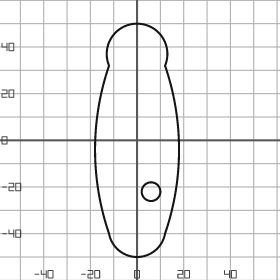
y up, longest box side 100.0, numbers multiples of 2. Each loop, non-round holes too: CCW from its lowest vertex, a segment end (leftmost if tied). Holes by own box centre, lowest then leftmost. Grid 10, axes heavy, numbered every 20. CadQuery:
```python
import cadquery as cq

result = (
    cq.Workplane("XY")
    .moveTo(-12.0, -40.0)
    .threePointArc((0.0, -50.0), (12.0, -40.0))
    .threePointArc((18.0, -4.0), (12.0, 32.0))
    .threePointArc((0.0, 50.0), (-12.0, 32.0))
    .threePointArc((-18.0, -4.0), (-12.0, -40.0))
    .close()
    .moveTo(6.0, -22.0)
    .circle(4.0)
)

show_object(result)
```